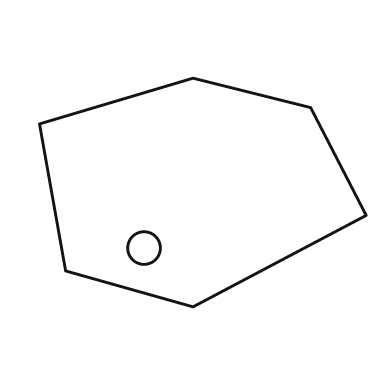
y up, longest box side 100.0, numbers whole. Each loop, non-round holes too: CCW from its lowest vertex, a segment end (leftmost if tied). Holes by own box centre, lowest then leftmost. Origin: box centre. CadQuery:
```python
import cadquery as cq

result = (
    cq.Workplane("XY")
    .moveTo(-3.0, -35.0)
    .lineTo(50.0, -7.0)
    .lineTo(33.0, 26.0)
    .lineTo(-3.0, 35.0)
    .lineTo(-50.0, 21.0)
    .lineTo(-42.0, -24.0)
    .close()
    .moveTo(-18.0, -17.0)
    .circle(5.0)
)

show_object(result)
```